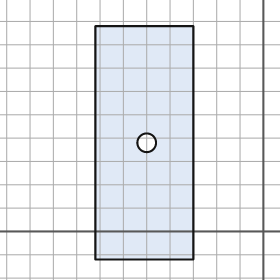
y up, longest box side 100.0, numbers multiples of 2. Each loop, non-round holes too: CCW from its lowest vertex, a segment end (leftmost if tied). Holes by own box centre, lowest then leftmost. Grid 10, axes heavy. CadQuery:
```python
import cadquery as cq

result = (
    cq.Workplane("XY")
    .moveTo(-72.0, -12.0)
    .lineTo(-30.0, -12.0)
    .lineTo(-30.0, 88.0)
    .lineTo(-72.0, 88.0)
    .close()
    .moveTo(-50.0, 38.0)
    .circle(4.0)
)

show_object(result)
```